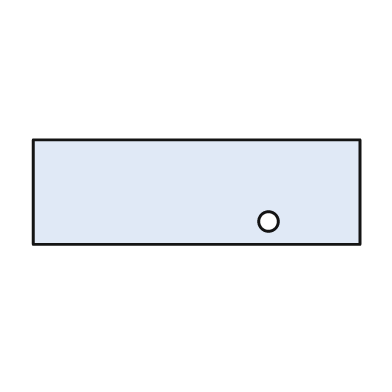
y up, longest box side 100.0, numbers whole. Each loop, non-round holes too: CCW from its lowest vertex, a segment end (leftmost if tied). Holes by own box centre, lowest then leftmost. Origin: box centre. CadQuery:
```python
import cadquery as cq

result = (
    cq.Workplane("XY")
    .moveTo(-50.0, -16.0)
    .lineTo(50.0, -16.0)
    .lineTo(50.0, 16.0)
    .lineTo(-50.0, 16.0)
    .close()
    .moveTo(22.0, -9.0)
    .circle(3.0)
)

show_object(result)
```